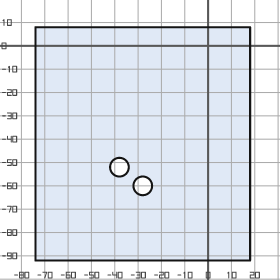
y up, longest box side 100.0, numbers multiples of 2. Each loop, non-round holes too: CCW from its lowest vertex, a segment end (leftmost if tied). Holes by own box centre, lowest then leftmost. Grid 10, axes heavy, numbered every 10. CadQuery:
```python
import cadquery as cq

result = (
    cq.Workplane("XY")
    .moveTo(-74.0, -92.0)
    .lineTo(18.0, -92.0)
    .lineTo(18.0, 8.0)
    .lineTo(-74.0, 8.0)
    .close()
    .moveTo(-28.0, -60.0)
    .circle(4.0)
    .moveTo(-38.0, -52.0)
    .circle(4.0)
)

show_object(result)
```